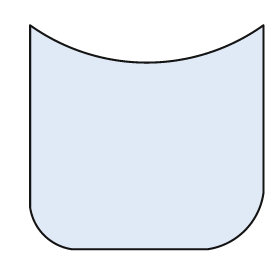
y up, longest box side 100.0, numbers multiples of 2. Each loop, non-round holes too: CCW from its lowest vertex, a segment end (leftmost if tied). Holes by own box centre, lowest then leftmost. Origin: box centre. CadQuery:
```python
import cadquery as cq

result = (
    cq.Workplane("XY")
    .moveTo(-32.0, -48.0)
    .lineTo(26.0, -48.0)
    .threePointArc((42.0, -40.0), (50.0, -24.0))
    .lineTo(50.0, 48.0)
    .threePointArc((0.0, 32.0), (-50.0, 48.0))
    .lineTo(-50.0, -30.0)
    .threePointArc((-44.0, -42.0), (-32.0, -48.0))
    .close()
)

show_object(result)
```